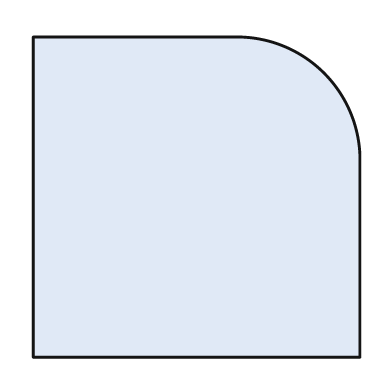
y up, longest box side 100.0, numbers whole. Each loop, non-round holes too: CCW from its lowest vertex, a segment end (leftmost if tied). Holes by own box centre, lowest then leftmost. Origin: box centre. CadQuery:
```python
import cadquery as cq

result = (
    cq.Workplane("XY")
    .moveTo(-50.0, -49.0)
    .lineTo(50.0, -49.0)
    .lineTo(50.0, 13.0)
    .threePointArc((39.0, 38.0), (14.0, 49.0))
    .lineTo(-50.0, 49.0)
    .close()
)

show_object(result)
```